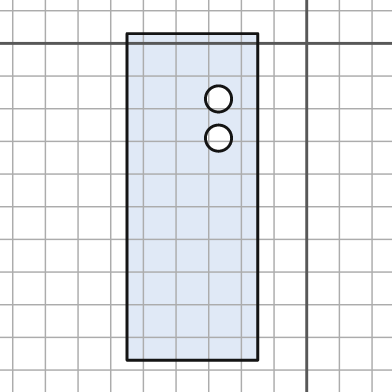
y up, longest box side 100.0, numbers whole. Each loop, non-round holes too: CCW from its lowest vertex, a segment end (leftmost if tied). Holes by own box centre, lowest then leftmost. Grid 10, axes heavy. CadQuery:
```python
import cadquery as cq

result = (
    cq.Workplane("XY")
    .moveTo(-55.0, -97.0)
    .lineTo(-15.0, -97.0)
    .lineTo(-15.0, 3.0)
    .lineTo(-55.0, 3.0)
    .close()
    .moveTo(-27.0, -29.0)
    .circle(4.0)
    .moveTo(-27.0, -17.0)
    .circle(4.0)
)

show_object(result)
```